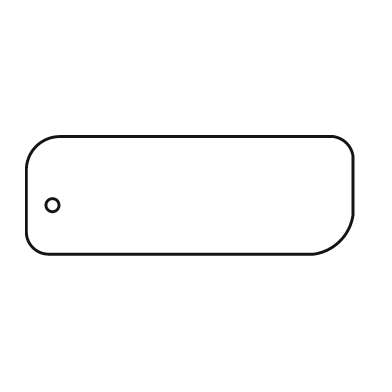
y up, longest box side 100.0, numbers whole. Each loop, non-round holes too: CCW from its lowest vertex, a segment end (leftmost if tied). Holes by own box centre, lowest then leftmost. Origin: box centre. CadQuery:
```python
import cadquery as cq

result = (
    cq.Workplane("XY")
    .moveTo(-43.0, -18.0)
    .lineTo(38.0, -18.0)
    .threePointArc((46.0, -14.0), (50.0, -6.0))
    .lineTo(50.0, 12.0)
    .threePointArc((48.0, 16.0), (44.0, 18.0))
    .lineTo(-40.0, 18.0)
    .threePointArc((-47.0, 15.0), (-50.0, 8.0))
    .lineTo(-50.0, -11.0)
    .threePointArc((-48.0, -16.0), (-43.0, -18.0))
    .close()
    .moveTo(-42.0, -3.0)
    .circle(2.0)
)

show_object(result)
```